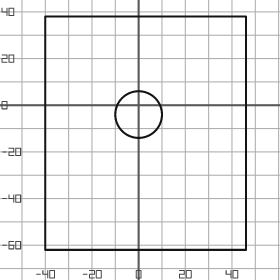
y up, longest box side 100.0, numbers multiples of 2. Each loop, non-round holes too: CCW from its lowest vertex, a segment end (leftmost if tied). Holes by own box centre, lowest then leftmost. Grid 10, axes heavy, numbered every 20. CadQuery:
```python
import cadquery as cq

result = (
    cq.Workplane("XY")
    .moveTo(-40.0, -62.0)
    .lineTo(46.0, -62.0)
    .lineTo(46.0, 38.0)
    .lineTo(-40.0, 38.0)
    .close()
    .moveTo(0.0, -4.0)
    .circle(10.0)
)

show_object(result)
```